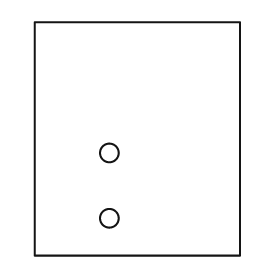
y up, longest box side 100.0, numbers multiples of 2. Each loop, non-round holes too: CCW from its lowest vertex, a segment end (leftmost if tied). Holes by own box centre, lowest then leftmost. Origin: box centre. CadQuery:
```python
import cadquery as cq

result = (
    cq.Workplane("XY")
    .moveTo(-44.0, -50.0)
    .lineTo(44.0, -50.0)
    .lineTo(44.0, 50.0)
    .lineTo(-44.0, 50.0)
    .close()
    .moveTo(-12.0, -34.0)
    .circle(4.0)
    .moveTo(-12.0, -6.0)
    .circle(4.0)
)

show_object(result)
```